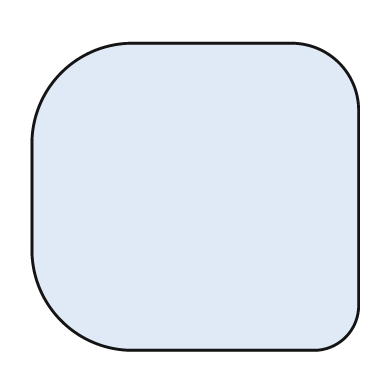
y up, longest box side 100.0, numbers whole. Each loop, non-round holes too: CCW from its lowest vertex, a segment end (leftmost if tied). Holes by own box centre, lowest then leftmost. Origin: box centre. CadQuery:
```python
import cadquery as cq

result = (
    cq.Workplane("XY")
    .moveTo(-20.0, -47.0)
    .lineTo(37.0, -47.0)
    .threePointArc((46.0, -43.0), (50.0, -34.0))
    .lineTo(50.0, 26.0)
    .threePointArc((44.0, 41.0), (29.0, 47.0))
    .lineTo(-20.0, 47.0)
    .threePointArc((-41.0, 38.0), (-50.0, 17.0))
    .lineTo(-50.0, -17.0)
    .threePointArc((-41.0, -38.0), (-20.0, -47.0))
    .close()
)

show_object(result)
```